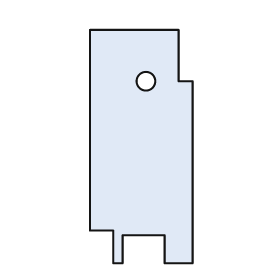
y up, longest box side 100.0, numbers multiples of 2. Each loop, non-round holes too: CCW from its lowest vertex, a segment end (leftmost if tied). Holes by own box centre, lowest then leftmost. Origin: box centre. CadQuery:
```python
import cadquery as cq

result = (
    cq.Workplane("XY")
    .moveTo(-12.0, -50.0)
    .lineTo(-8.0, -50.0)
    .lineTo(-8.0, -38.0)
    .lineTo(10.0, -38.0)
    .lineTo(10.0, -50.0)
    .lineTo(22.0, -50.0)
    .lineTo(22.0, 28.0)
    .lineTo(16.0, 28.0)
    .lineTo(16.0, 50.0)
    .lineTo(-22.0, 50.0)
    .lineTo(-22.0, -36.0)
    .lineTo(-12.0, -36.0)
    .close()
    .moveTo(2.0, 28.0)
    .circle(4.0)
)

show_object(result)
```